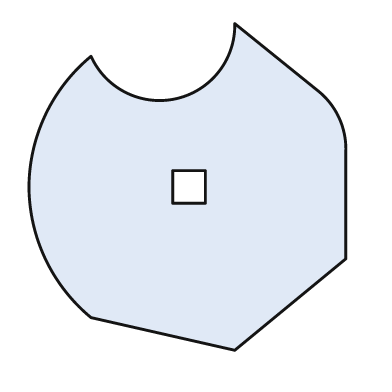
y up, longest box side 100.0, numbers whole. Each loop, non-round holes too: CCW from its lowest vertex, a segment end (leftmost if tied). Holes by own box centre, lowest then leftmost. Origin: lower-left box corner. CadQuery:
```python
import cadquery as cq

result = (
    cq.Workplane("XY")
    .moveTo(63.0, 0.0)
    .lineTo(97.0, 28.0)
    .lineTo(97.0, 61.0)
    .threePointArc((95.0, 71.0), (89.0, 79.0))
    .lineTo(63.0, 100.0)
    .threePointArc((45.0, 77.0), (19.0, 90.0))
    .threePointArc((5.0, 72.0), (0.0, 50.0))
    .threePointArc((5.0, 28.0), (19.0, 10.0))
    .close()
    .moveTo(44.0, 45.0)
    .lineTo(54.0, 45.0)
    .lineTo(54.0, 55.0)
    .lineTo(44.0, 55.0)
    .close()
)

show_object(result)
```